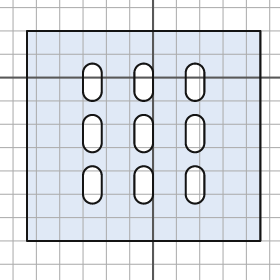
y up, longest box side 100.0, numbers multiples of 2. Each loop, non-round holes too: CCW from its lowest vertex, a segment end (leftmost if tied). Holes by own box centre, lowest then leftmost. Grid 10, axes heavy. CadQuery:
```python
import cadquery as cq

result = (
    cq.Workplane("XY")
    .moveTo(-54.0, -70.0)
    .lineTo(46.0, -70.0)
    .lineTo(46.0, 20.0)
    .lineTo(-54.0, 20.0)
    .close()
    .moveTo(-30.0, -50.0)
    .threePointArc((-26.0, -54.0), (-22.0, -50.0))
    .lineTo(-22.0, -42.0)
    .threePointArc((-26.0, -38.0), (-30.0, -42.0))
    .close()
    .moveTo(-8.0, -50.0)
    .threePointArc((-4.0, -54.0), (0.0, -50.0))
    .lineTo(0.0, -42.0)
    .threePointArc((-4.0, -38.0), (-8.0, -42.0))
    .close()
    .moveTo(14.0, -50.0)
    .threePointArc((18.0, -54.0), (22.0, -50.0))
    .lineTo(22.0, -42.0)
    .threePointArc((18.0, -38.0), (14.0, -42.0))
    .close()
    .moveTo(-30.0, -28.0)
    .threePointArc((-26.0, -32.0), (-22.0, -28.0))
    .lineTo(-22.0, -20.0)
    .threePointArc((-26.0, -16.0), (-30.0, -20.0))
    .close()
    .moveTo(-8.0, -28.0)
    .threePointArc((-4.0, -32.0), (0.0, -28.0))
    .lineTo(0.0, -20.0)
    .threePointArc((-4.0, -16.0), (-8.0, -20.0))
    .close()
    .moveTo(14.0, -28.0)
    .threePointArc((18.0, -32.0), (22.0, -28.0))
    .lineTo(22.0, -20.0)
    .threePointArc((18.0, -16.0), (14.0, -20.0))
    .close()
    .moveTo(-30.0, -6.0)
    .threePointArc((-26.0, -10.0), (-22.0, -6.0))
    .lineTo(-22.0, 2.0)
    .threePointArc((-26.0, 6.0), (-30.0, 2.0))
    .close()
    .moveTo(-8.0, -6.0)
    .threePointArc((-4.0, -10.0), (0.0, -6.0))
    .lineTo(0.0, 2.0)
    .threePointArc((-4.0, 6.0), (-8.0, 2.0))
    .close()
    .moveTo(14.0, -6.0)
    .threePointArc((18.0, -10.0), (22.0, -6.0))
    .lineTo(22.0, 2.0)
    .threePointArc((18.0, 6.0), (14.0, 2.0))
    .close()
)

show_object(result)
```